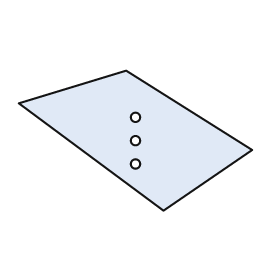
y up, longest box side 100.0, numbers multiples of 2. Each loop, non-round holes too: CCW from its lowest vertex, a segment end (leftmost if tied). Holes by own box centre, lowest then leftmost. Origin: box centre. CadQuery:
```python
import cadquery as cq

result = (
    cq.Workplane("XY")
    .moveTo(12.0, -30.0)
    .lineTo(50.0, -4.0)
    .lineTo(-4.0, 30.0)
    .lineTo(-50.0, 16.0)
    .close()
    .moveTo(0.0, -10.0)
    .circle(2.0)
    .moveTo(0.0, 0.0)
    .circle(2.0)
    .moveTo(0.0, 10.0)
    .circle(2.0)
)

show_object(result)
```